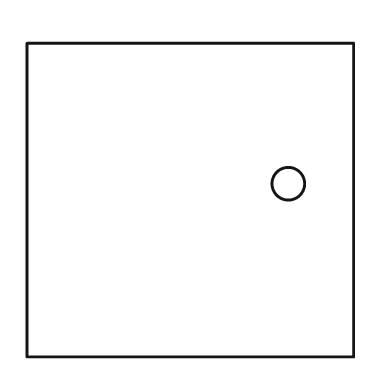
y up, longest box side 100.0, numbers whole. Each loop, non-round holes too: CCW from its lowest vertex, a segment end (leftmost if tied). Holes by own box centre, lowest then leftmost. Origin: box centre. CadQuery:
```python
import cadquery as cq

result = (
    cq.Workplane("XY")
    .moveTo(-50.0, -48.0)
    .lineTo(50.0, -48.0)
    .lineTo(50.0, 48.0)
    .lineTo(-50.0, 48.0)
    .close()
    .moveTo(30.0, 5.0)
    .circle(5.0)
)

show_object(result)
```